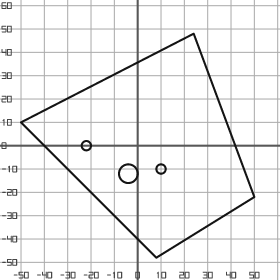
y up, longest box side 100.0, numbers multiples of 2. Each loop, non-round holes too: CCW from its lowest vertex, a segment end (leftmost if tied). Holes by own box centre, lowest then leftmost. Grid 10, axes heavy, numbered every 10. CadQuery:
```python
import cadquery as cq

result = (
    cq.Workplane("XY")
    .moveTo(8.0, -48.0)
    .lineTo(50.0, -22.0)
    .lineTo(24.0, 48.0)
    .lineTo(-50.0, 10.0)
    .close()
    .moveTo(-4.0, -12.0)
    .circle(4.0)
    .moveTo(10.0, -10.0)
    .circle(2.0)
    .moveTo(-22.0, 0.0)
    .circle(2.0)
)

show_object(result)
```